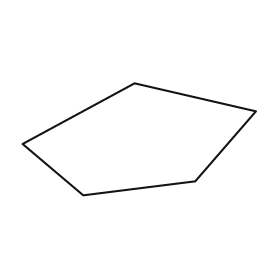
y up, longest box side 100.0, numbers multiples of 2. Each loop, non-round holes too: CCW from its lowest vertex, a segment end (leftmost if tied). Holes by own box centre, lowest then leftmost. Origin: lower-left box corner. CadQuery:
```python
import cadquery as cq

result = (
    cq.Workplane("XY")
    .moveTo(26.0, 0.0)
    .lineTo(74.0, 6.0)
    .lineTo(100.0, 36.0)
    .lineTo(48.0, 48.0)
    .lineTo(0.0, 22.0)
    .close()
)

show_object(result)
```